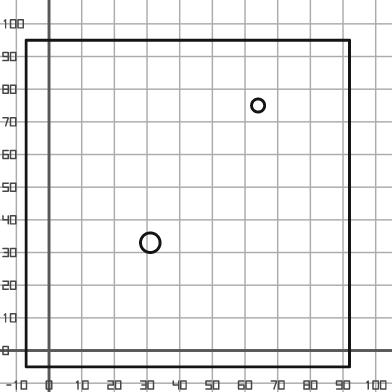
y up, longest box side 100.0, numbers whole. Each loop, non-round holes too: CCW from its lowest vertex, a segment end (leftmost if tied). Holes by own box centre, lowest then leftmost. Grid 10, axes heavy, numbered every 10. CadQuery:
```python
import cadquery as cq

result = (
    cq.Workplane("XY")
    .moveTo(-7.0, -5.0)
    .lineTo(92.0, -5.0)
    .lineTo(92.0, 95.0)
    .lineTo(-7.0, 95.0)
    .close()
    .moveTo(31.0, 33.0)
    .circle(3.0)
    .moveTo(64.0, 75.0)
    .circle(2.0)
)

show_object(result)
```